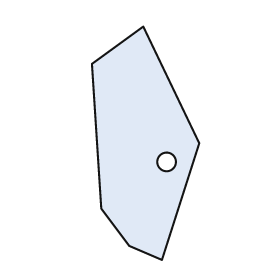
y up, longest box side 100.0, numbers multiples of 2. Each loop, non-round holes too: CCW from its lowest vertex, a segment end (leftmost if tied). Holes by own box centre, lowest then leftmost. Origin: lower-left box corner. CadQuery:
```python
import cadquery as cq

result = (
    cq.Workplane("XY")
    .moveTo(30.0, 0.0)
    .lineTo(46.0, 50.0)
    .lineTo(22.0, 100.0)
    .lineTo(0.0, 84.0)
    .lineTo(4.0, 22.0)
    .lineTo(16.0, 6.0)
    .close()
    .moveTo(32.0, 42.0)
    .circle(4.0)
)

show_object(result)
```